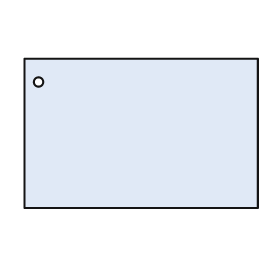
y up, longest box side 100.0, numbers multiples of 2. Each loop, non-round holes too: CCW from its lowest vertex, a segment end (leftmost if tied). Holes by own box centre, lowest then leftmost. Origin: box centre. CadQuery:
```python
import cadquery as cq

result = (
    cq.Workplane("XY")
    .moveTo(-50.0, -32.0)
    .lineTo(50.0, -32.0)
    .lineTo(50.0, 32.0)
    .lineTo(-50.0, 32.0)
    .close()
    .moveTo(-44.0, 22.0)
    .circle(2.0)
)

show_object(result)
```